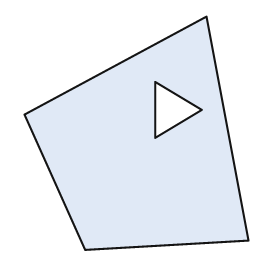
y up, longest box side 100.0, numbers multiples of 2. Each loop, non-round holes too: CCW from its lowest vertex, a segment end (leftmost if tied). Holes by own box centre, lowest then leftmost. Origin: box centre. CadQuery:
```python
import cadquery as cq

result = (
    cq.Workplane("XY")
    .moveTo(-22.0, -50.0)
    .lineTo(48.0, -46.0)
    .lineTo(30.0, 50.0)
    .lineTo(-48.0, 8.0)
    .close()
    .moveTo(8.0, -2.0)
    .lineTo(28.0, 10.0)
    .lineTo(8.0, 22.0)
    .close()
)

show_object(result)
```